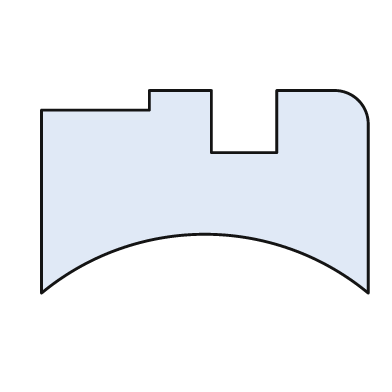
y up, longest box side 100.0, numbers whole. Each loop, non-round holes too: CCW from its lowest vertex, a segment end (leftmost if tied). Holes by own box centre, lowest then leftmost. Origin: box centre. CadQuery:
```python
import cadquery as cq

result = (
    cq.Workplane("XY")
    .moveTo(-50.0, -31.0)
    .threePointArc((0.0, -13.0), (50.0, -31.0))
    .lineTo(50.0, 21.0)
    .threePointArc((47.0, 28.0), (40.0, 31.0))
    .lineTo(22.0, 31.0)
    .lineTo(22.0, 12.0)
    .lineTo(2.0, 12.0)
    .lineTo(2.0, 31.0)
    .lineTo(-17.0, 31.0)
    .lineTo(-17.0, 25.0)
    .lineTo(-50.0, 25.0)
    .close()
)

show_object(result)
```